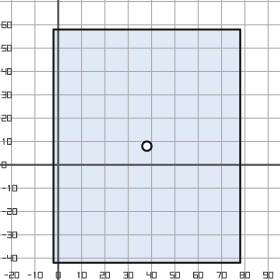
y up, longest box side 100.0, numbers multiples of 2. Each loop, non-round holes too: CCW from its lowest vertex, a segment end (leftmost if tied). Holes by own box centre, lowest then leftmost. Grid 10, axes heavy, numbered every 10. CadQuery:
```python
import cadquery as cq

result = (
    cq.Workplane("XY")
    .moveTo(-2.0, -42.0)
    .lineTo(78.0, -42.0)
    .lineTo(78.0, 58.0)
    .lineTo(-2.0, 58.0)
    .close()
    .moveTo(38.0, 8.0)
    .circle(2.0)
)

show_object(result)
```